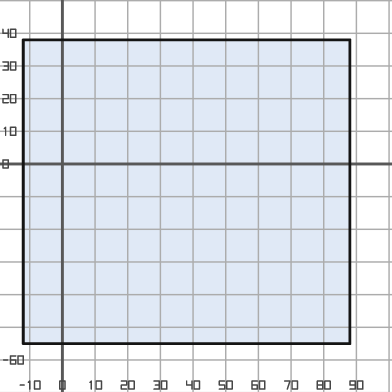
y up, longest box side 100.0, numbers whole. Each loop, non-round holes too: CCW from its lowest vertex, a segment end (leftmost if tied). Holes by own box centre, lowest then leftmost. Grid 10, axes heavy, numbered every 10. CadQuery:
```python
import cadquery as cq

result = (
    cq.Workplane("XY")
    .moveTo(-12.0, -55.0)
    .lineTo(88.0, -55.0)
    .lineTo(88.0, 38.0)
    .lineTo(-12.0, 38.0)
    .close()
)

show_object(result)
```